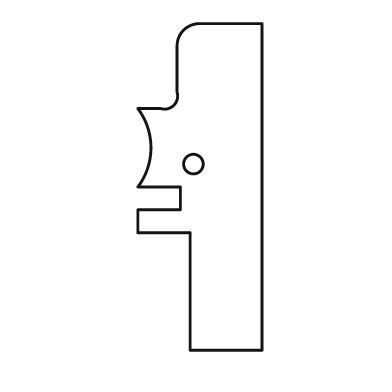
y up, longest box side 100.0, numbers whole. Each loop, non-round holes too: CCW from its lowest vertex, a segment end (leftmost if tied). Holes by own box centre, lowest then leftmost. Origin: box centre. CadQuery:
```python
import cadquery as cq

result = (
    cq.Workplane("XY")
    .moveTo(-3.0, -50.0)
    .lineTo(19.0, -50.0)
    .lineTo(19.0, 50.0)
    .lineTo(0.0, 50.0)
    .threePointArc((-5.0, 48.0), (-7.0, 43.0))
    .lineTo(-7.0, 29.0)
    .threePointArc((-8.0, 25.0), (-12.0, 24.0))
    .lineTo(-19.0, 24.0)
    .threePointArc((-15.0, 12.0), (-19.0, 0.0))
    .lineTo(-6.0, 0.0)
    .lineTo(-6.0, -7.0)
    .lineTo(-19.0, -7.0)
    .lineTo(-19.0, -14.0)
    .lineTo(-3.0, -14.0)
    .close()
    .moveTo(-2.0, 7.0)
    .circle(3.0)
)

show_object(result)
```